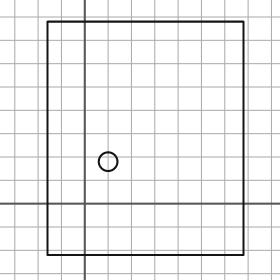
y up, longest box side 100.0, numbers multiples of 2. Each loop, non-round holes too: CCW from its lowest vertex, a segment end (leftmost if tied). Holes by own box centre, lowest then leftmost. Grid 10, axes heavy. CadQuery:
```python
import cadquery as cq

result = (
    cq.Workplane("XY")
    .moveTo(-16.0, -22.0)
    .lineTo(68.0, -22.0)
    .lineTo(68.0, 78.0)
    .lineTo(-16.0, 78.0)
    .close()
    .moveTo(10.0, 18.0)
    .circle(4.0)
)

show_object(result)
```